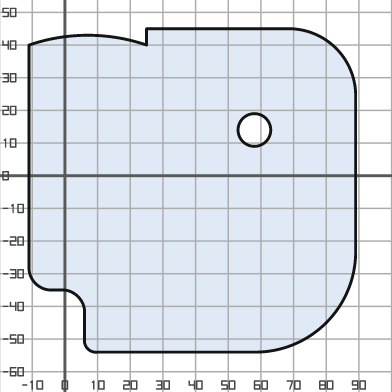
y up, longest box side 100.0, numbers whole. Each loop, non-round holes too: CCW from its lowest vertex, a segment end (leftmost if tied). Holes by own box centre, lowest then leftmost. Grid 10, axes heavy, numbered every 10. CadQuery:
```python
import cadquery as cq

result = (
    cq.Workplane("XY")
    .moveTo(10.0, -54.0)
    .lineTo(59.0, -54.0)
    .threePointArc((80.0, -45.0), (89.0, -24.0))
    .lineTo(89.0, 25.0)
    .threePointArc((83.0, 39.0), (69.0, 45.0))
    .lineTo(25.0, 45.0)
    .lineTo(25.0, 40.0)
    .threePointArc((7.0, 43.0), (-11.0, 40.0))
    .lineTo(-11.0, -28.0)
    .threePointArc((-9.0, -33.0), (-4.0, -35.0))
    .lineTo(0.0, -35.0)
    .threePointArc((4.0, -37.0), (6.0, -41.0))
    .lineTo(6.0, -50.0)
    .threePointArc((7.0, -53.0), (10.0, -54.0))
    .close()
    .moveTo(58.0, 14.0)
    .circle(5.0)
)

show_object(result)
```